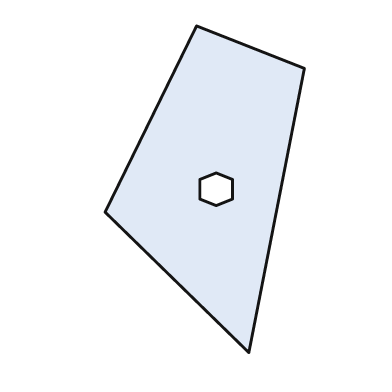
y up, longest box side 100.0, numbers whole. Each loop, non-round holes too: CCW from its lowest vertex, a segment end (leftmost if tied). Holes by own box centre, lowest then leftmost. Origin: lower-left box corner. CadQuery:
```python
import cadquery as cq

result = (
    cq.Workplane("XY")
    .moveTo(44.0, 0.0)
    .lineTo(61.0, 87.0)
    .lineTo(28.0, 100.0)
    .lineTo(0.0, 43.0)
    .close()
    .moveTo(34.0, 45.0)
    .lineTo(39.0, 47.0)
    .lineTo(39.0, 53.0)
    .lineTo(34.0, 55.0)
    .lineTo(29.0, 53.0)
    .lineTo(29.0, 47.0)
    .close()
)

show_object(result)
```